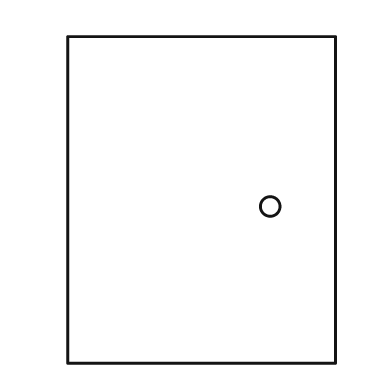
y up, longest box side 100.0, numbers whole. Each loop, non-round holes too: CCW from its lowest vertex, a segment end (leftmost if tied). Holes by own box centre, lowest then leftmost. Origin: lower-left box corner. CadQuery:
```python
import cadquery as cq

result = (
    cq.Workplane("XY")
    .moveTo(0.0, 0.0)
    .lineTo(82.0, 0.0)
    .lineTo(82.0, 100.0)
    .lineTo(0.0, 100.0)
    .close()
    .moveTo(62.0, 48.0)
    .circle(3.0)
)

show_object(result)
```